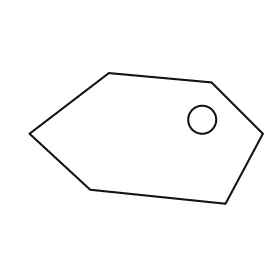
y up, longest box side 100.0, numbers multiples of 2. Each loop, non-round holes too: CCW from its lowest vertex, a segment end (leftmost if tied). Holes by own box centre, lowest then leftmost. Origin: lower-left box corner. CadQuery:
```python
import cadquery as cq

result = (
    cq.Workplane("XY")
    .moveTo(84.0, 0.0)
    .lineTo(100.0, 30.0)
    .lineTo(78.0, 52.0)
    .lineTo(34.0, 56.0)
    .lineTo(0.0, 30.0)
    .lineTo(26.0, 6.0)
    .close()
    .moveTo(74.0, 36.0)
    .circle(6.0)
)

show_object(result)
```